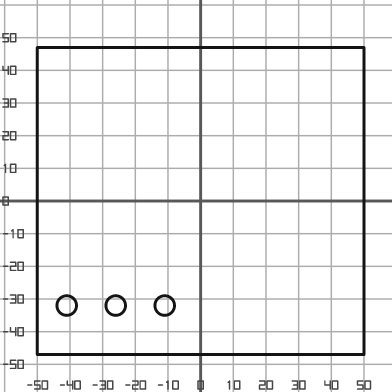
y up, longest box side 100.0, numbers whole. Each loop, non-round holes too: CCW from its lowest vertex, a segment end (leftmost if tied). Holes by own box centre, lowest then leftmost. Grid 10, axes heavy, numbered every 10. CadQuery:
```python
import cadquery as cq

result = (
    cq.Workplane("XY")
    .moveTo(-50.0, -47.0)
    .lineTo(50.0, -47.0)
    .lineTo(50.0, 47.0)
    .lineTo(-50.0, 47.0)
    .close()
    .moveTo(-41.0, -32.0)
    .circle(3.0)
    .moveTo(-26.0, -32.0)
    .circle(3.0)
    .moveTo(-11.0, -32.0)
    .circle(3.0)
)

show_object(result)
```